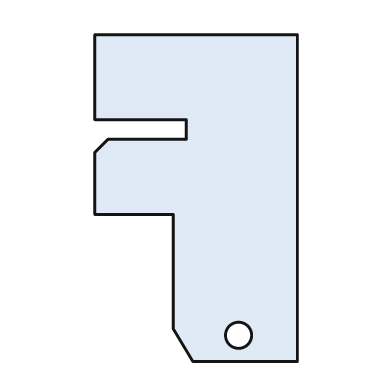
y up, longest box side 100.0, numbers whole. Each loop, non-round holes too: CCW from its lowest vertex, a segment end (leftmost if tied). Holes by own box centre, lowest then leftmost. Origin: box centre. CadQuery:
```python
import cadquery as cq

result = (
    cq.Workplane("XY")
    .moveTo(-1.0, -50.0)
    .lineTo(31.0, -50.0)
    .lineTo(31.0, 50.0)
    .lineTo(-31.0, 50.0)
    .lineTo(-31.0, 24.0)
    .lineTo(-3.0, 24.0)
    .lineTo(-3.0, 18.0)
    .lineTo(-27.0, 18.0)
    .lineTo(-31.0, 14.0)
    .lineTo(-31.0, -5.0)
    .lineTo(-7.0, -5.0)
    .lineTo(-7.0, -40.0)
    .close()
    .moveTo(13.0, -42.0)
    .circle(4.0)
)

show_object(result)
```